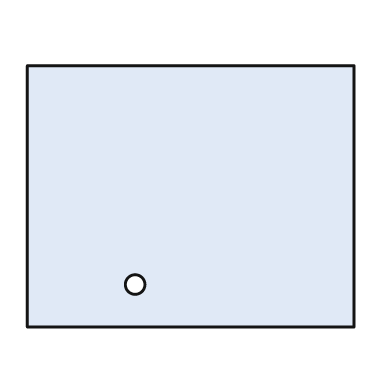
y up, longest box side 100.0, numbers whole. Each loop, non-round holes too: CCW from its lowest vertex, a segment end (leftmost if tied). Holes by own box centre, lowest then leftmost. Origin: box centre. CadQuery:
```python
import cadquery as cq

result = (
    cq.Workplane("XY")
    .moveTo(-50.0, -40.0)
    .lineTo(50.0, -40.0)
    .lineTo(50.0, 40.0)
    .lineTo(-50.0, 40.0)
    .close()
    .moveTo(-17.0, -27.0)
    .circle(3.0)
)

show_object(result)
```